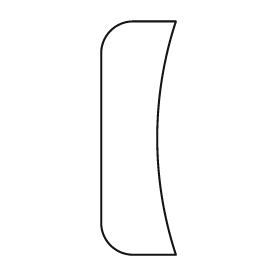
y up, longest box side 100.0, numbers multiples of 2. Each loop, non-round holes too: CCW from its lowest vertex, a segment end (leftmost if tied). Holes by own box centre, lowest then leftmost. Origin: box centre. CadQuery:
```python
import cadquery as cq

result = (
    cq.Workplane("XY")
    .moveTo(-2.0, -50.0)
    .lineTo(16.0, -50.0)
    .threePointArc((8.0, 0.0), (16.0, 50.0))
    .lineTo(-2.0, 50.0)
    .threePointArc((-12.0, 46.0), (-16.0, 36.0))
    .lineTo(-16.0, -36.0)
    .threePointArc((-12.0, -46.0), (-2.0, -50.0))
    .close()
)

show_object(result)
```